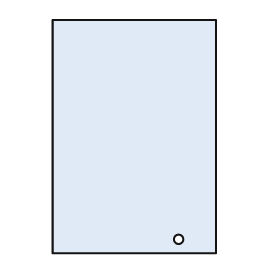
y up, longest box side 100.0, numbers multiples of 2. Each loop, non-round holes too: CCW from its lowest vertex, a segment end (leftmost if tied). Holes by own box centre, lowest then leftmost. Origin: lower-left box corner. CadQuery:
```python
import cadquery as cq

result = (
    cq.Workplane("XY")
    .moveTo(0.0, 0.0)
    .lineTo(70.0, 0.0)
    .lineTo(70.0, 100.0)
    .lineTo(0.0, 100.0)
    .close()
    .moveTo(54.0, 6.0)
    .circle(2.0)
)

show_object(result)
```